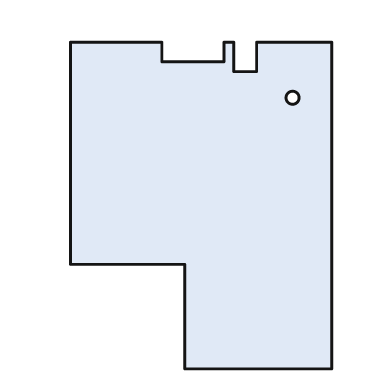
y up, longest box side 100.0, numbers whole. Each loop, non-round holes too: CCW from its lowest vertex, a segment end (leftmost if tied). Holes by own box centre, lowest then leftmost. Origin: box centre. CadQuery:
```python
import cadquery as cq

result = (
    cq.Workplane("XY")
    .moveTo(-5.0, -50.0)
    .lineTo(40.0, -50.0)
    .lineTo(40.0, 50.0)
    .lineTo(17.0, 50.0)
    .lineTo(17.0, 41.0)
    .lineTo(10.0, 41.0)
    .lineTo(10.0, 50.0)
    .lineTo(7.0, 50.0)
    .lineTo(7.0, 44.0)
    .lineTo(-12.0, 44.0)
    .lineTo(-12.0, 50.0)
    .lineTo(-40.0, 50.0)
    .lineTo(-40.0, -18.0)
    .lineTo(-5.0, -18.0)
    .close()
    .moveTo(28.0, 33.0)
    .circle(2.0)
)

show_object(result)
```